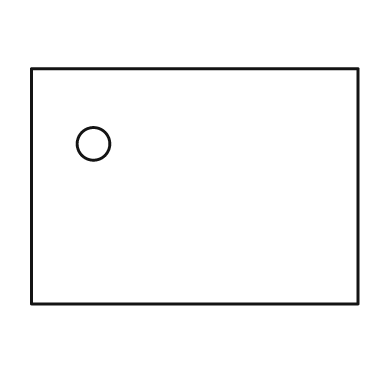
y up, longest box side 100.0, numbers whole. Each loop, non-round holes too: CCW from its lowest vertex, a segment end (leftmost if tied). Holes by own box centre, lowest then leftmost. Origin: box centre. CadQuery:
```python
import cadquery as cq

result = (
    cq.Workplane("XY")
    .moveTo(-50.0, -36.0)
    .lineTo(50.0, -36.0)
    .lineTo(50.0, 36.0)
    .lineTo(-50.0, 36.0)
    .close()
    .moveTo(-31.0, 13.0)
    .circle(5.0)
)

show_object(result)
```